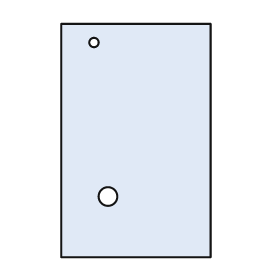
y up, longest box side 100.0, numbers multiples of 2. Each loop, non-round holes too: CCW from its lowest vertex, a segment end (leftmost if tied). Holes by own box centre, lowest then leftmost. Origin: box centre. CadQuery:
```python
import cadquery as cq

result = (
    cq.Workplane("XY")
    .moveTo(-32.0, -50.0)
    .lineTo(32.0, -50.0)
    .lineTo(32.0, 50.0)
    .lineTo(-32.0, 50.0)
    .close()
    .moveTo(-12.0, -24.0)
    .circle(4.0)
    .moveTo(-18.0, 42.0)
    .circle(2.0)
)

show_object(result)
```